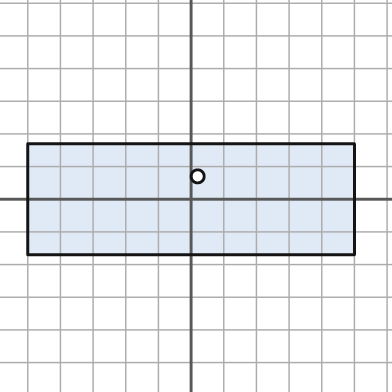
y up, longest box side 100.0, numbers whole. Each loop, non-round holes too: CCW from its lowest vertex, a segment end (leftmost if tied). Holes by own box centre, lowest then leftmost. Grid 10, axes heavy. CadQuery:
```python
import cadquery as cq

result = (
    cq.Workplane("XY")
    .moveTo(-50.0, -17.0)
    .lineTo(50.0, -17.0)
    .lineTo(50.0, 17.0)
    .lineTo(-50.0, 17.0)
    .close()
    .moveTo(2.0, 7.0)
    .circle(2.0)
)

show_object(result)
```